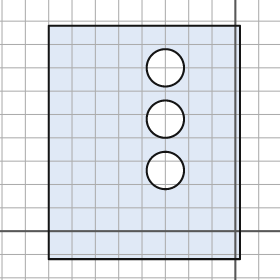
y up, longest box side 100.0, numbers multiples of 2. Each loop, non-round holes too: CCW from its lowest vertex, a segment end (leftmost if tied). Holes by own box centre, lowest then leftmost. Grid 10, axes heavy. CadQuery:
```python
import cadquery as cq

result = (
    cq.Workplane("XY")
    .moveTo(-80.0, -12.0)
    .lineTo(2.0, -12.0)
    .lineTo(2.0, 88.0)
    .lineTo(-80.0, 88.0)
    .close()
    .moveTo(-30.0, 26.0)
    .circle(8.0)
    .moveTo(-30.0, 48.0)
    .circle(8.0)
    .moveTo(-30.0, 70.0)
    .circle(8.0)
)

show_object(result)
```